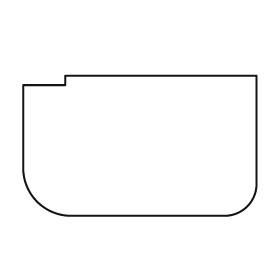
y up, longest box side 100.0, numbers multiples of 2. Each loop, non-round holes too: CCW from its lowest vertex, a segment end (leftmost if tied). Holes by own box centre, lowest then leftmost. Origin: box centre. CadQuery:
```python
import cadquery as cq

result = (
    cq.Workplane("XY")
    .moveTo(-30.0, -30.0)
    .lineTo(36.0, -30.0)
    .threePointArc((46.0, -26.0), (50.0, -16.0))
    .lineTo(50.0, 30.0)
    .lineTo(-32.0, 30.0)
    .lineTo(-32.0, 26.0)
    .lineTo(-50.0, 26.0)
    .lineTo(-50.0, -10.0)
    .threePointArc((-44.0, -24.0), (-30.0, -30.0))
    .close()
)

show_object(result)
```